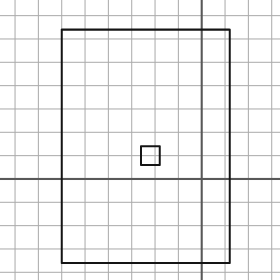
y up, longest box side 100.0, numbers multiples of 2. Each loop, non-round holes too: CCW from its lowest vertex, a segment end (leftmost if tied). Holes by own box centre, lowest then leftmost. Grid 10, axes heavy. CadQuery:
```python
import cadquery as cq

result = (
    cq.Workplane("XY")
    .moveTo(-60.0, -36.0)
    .lineTo(12.0, -36.0)
    .lineTo(12.0, 64.0)
    .lineTo(-60.0, 64.0)
    .close()
    .moveTo(-26.0, 6.0)
    .lineTo(-18.0, 6.0)
    .lineTo(-18.0, 14.0)
    .lineTo(-26.0, 14.0)
    .close()
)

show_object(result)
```